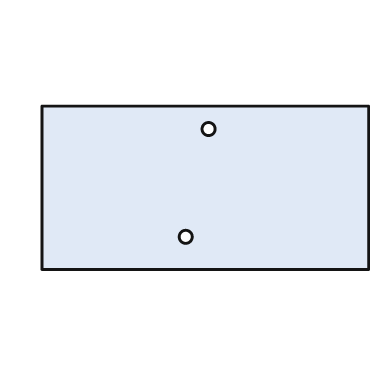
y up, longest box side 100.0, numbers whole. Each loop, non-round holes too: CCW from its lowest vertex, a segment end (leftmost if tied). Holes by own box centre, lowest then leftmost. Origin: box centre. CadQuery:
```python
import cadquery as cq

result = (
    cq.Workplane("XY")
    .moveTo(-50.0, -25.0)
    .lineTo(50.0, -25.0)
    .lineTo(50.0, 25.0)
    .lineTo(-50.0, 25.0)
    .close()
    .moveTo(-6.0, -15.0)
    .circle(2.0)
    .moveTo(1.0, 18.0)
    .circle(2.0)
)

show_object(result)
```